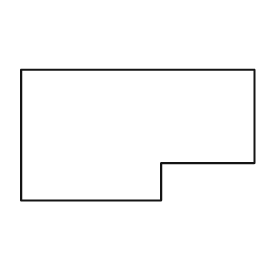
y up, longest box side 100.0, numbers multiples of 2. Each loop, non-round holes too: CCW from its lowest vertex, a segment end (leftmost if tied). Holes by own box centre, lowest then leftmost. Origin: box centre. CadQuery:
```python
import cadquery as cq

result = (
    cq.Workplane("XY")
    .moveTo(-50.0, -28.0)
    .lineTo(10.0, -28.0)
    .lineTo(10.0, -12.0)
    .lineTo(50.0, -12.0)
    .lineTo(50.0, 28.0)
    .lineTo(-50.0, 28.0)
    .close()
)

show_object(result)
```